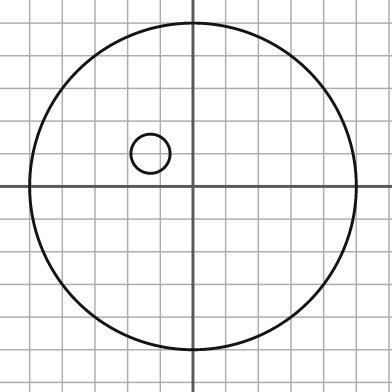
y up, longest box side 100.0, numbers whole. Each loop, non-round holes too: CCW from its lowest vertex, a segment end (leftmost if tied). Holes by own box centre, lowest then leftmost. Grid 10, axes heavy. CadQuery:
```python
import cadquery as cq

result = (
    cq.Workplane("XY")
    .moveTo(0.0, 0.0)
    .circle(50.0)
    .moveTo(-13.0, 10.0)
    .circle(6.0)
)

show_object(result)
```